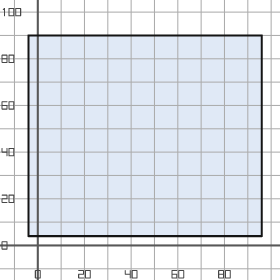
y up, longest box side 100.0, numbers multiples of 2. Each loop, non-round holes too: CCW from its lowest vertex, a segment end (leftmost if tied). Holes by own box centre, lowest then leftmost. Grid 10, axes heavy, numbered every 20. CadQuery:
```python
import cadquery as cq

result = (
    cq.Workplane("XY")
    .moveTo(-4.0, 4.0)
    .lineTo(96.0, 4.0)
    .lineTo(96.0, 90.0)
    .lineTo(-4.0, 90.0)
    .close()
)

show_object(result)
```